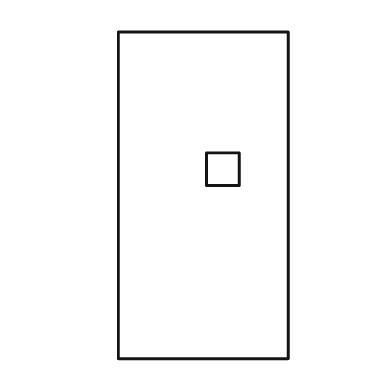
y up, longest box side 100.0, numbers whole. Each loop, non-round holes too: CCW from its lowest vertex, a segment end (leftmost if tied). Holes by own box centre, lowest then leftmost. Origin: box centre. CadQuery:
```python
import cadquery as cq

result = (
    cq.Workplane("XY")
    .moveTo(-26.0, -50.0)
    .lineTo(26.0, -50.0)
    .lineTo(26.0, 50.0)
    .lineTo(-26.0, 50.0)
    .close()
    .moveTo(1.0, 3.0)
    .lineTo(11.0, 3.0)
    .lineTo(11.0, 13.0)
    .lineTo(1.0, 13.0)
    .close()
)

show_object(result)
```